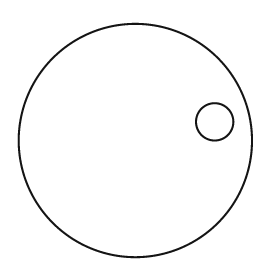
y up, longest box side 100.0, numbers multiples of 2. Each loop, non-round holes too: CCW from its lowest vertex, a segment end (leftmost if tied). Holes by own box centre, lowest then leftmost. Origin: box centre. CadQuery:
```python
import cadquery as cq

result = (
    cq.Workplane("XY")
    .moveTo(0.0, 0.0)
    .circle(50.0)
    .moveTo(34.0, 8.0)
    .circle(8.0)
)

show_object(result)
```